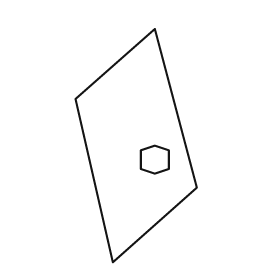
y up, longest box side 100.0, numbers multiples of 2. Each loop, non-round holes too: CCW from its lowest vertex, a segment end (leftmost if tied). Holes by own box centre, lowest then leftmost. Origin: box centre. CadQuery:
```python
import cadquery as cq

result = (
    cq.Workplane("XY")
    .moveTo(-10.0, -50.0)
    .lineTo(26.0, -18.0)
    .lineTo(8.0, 50.0)
    .lineTo(-26.0, 20.0)
    .close()
    .moveTo(8.0, -12.0)
    .lineTo(14.0, -10.0)
    .lineTo(14.0, -2.0)
    .lineTo(8.0, 0.0)
    .lineTo(2.0, -2.0)
    .lineTo(2.0, -10.0)
    .close()
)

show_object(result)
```